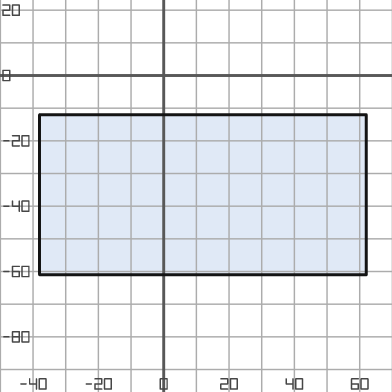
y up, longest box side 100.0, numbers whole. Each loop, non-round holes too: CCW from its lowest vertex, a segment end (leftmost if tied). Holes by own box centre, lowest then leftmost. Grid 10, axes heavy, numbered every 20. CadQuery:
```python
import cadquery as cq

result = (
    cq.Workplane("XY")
    .moveTo(-38.0, -61.0)
    .lineTo(62.0, -61.0)
    .lineTo(62.0, -12.0)
    .lineTo(-38.0, -12.0)
    .close()
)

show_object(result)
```